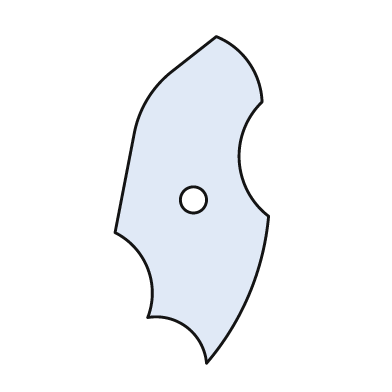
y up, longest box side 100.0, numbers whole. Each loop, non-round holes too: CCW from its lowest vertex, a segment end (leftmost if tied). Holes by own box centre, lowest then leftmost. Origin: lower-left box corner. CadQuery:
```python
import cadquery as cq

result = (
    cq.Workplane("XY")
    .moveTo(28.0, 0.0)
    .threePointArc((41.0, 21.0), (47.0, 45.0))
    .threePointArc((38.0, 62.0), (45.0, 80.0))
    .threePointArc((41.0, 92.0), (31.0, 100.0))
    .lineTo(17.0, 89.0)
    .threePointArc((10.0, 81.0), (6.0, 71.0))
    .lineTo(0.0, 40.0)
    .threePointArc((10.0, 29.0), (10.0, 14.0))
    .threePointArc((22.0, 11.0), (28.0, 0.0))
    .close()
    .moveTo(24.0, 50.0)
    .circle(4.0)
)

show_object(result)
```